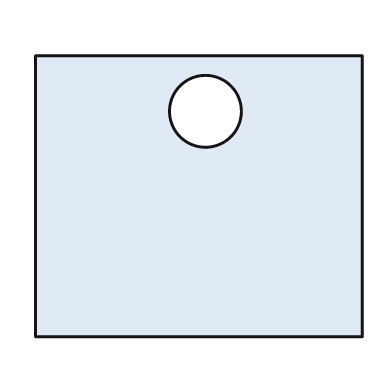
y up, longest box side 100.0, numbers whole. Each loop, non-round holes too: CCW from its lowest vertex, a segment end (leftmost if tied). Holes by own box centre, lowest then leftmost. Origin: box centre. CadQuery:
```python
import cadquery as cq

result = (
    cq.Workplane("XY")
    .moveTo(-50.0, -43.0)
    .lineTo(50.0, -43.0)
    .lineTo(50.0, 43.0)
    .lineTo(-50.0, 43.0)
    .close()
    .moveTo(2.0, 26.0)
    .circle(11.0)
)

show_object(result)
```